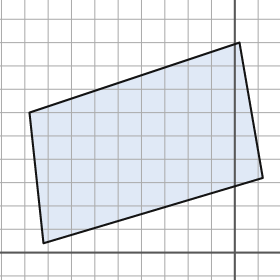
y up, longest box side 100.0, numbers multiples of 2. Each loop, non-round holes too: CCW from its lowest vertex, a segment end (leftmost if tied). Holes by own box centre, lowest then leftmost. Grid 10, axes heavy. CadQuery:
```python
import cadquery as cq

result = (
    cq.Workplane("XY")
    .moveTo(-82.0, 4.0)
    .lineTo(12.0, 32.0)
    .lineTo(2.0, 90.0)
    .lineTo(-88.0, 60.0)
    .close()
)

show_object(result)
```